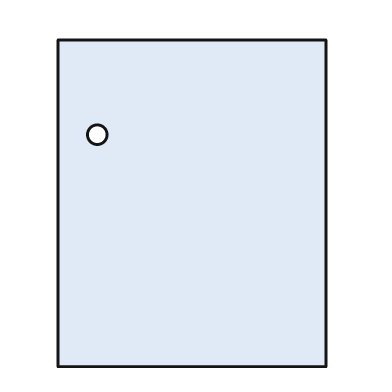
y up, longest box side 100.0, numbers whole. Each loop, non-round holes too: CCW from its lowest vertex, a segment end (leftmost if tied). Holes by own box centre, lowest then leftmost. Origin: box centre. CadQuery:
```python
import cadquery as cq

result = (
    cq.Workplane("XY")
    .moveTo(-41.0, -50.0)
    .lineTo(41.0, -50.0)
    .lineTo(41.0, 50.0)
    .lineTo(-41.0, 50.0)
    .close()
    .moveTo(-29.0, 21.0)
    .circle(3.0)
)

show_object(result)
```